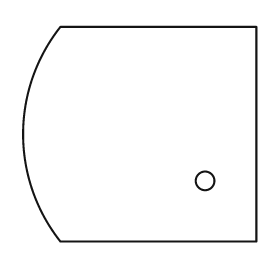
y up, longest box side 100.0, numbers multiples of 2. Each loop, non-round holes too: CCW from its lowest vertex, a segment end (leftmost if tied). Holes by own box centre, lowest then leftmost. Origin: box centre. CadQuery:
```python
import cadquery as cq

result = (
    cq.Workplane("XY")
    .moveTo(-34.0, -46.0)
    .lineTo(50.0, -46.0)
    .lineTo(50.0, 46.0)
    .lineTo(-34.0, 46.0)
    .threePointArc((-50.0, 0.0), (-34.0, -46.0))
    .close()
    .moveTo(28.0, -20.0)
    .circle(4.0)
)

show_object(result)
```